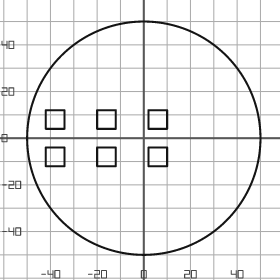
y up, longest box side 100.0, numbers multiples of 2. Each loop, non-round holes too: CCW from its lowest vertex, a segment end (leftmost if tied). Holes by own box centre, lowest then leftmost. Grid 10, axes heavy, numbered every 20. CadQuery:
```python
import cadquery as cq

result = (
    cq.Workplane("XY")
    .moveTo(0.0, 0.0)
    .circle(50.0)
    .moveTo(-42.0, -12.0)
    .lineTo(-34.0, -12.0)
    .lineTo(-34.0, -4.0)
    .lineTo(-42.0, -4.0)
    .close()
    .moveTo(-20.0, -12.0)
    .lineTo(-12.0, -12.0)
    .lineTo(-12.0, -4.0)
    .lineTo(-20.0, -4.0)
    .close()
    .moveTo(2.0, -12.0)
    .lineTo(10.0, -12.0)
    .lineTo(10.0, -4.0)
    .lineTo(2.0, -4.0)
    .close()
    .moveTo(-42.0, 4.0)
    .lineTo(-34.0, 4.0)
    .lineTo(-34.0, 12.0)
    .lineTo(-42.0, 12.0)
    .close()
    .moveTo(-20.0, 4.0)
    .lineTo(-12.0, 4.0)
    .lineTo(-12.0, 12.0)
    .lineTo(-20.0, 12.0)
    .close()
    .moveTo(2.0, 4.0)
    .lineTo(10.0, 4.0)
    .lineTo(10.0, 12.0)
    .lineTo(2.0, 12.0)
    .close()
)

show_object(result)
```